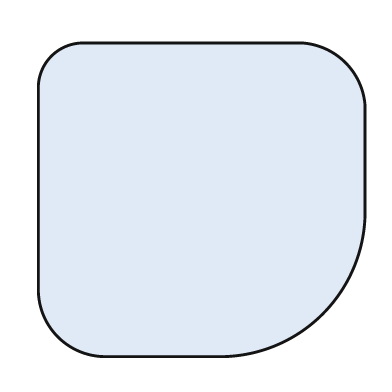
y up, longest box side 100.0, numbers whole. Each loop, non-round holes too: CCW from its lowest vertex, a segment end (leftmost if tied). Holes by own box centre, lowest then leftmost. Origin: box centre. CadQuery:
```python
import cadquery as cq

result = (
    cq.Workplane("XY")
    .moveTo(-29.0, -48.0)
    .lineTo(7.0, -48.0)
    .threePointArc((37.0, -35.0), (50.0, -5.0))
    .lineTo(50.0, 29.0)
    .threePointArc((44.0, 42.0), (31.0, 48.0))
    .lineTo(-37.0, 48.0)
    .threePointArc((-46.0, 44.0), (-50.0, 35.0))
    .lineTo(-50.0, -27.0)
    .threePointArc((-44.0, -42.0), (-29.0, -48.0))
    .close()
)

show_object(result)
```